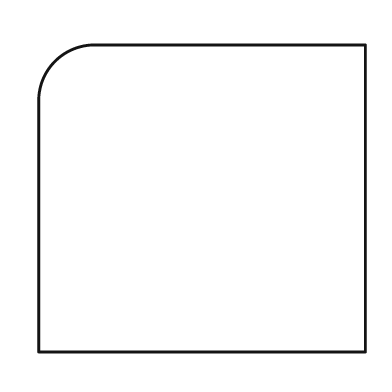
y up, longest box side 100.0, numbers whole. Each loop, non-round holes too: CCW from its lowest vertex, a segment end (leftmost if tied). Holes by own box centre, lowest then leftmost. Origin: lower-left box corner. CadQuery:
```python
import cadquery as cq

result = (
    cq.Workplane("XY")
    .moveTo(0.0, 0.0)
    .lineTo(100.0, 0.0)
    .lineTo(100.0, 94.0)
    .lineTo(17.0, 94.0)
    .threePointArc((5.0, 89.0), (0.0, 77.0))
    .close()
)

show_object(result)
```